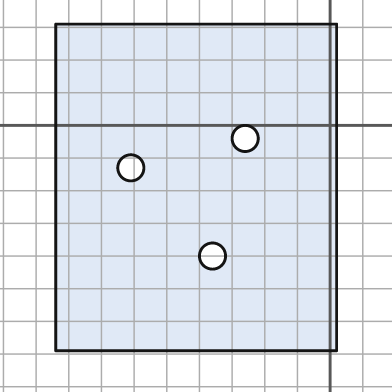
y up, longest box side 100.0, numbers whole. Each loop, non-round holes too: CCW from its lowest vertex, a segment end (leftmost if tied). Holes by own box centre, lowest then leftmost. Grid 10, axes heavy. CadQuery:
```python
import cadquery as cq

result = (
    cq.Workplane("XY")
    .moveTo(-84.0, -69.0)
    .lineTo(2.0, -69.0)
    .lineTo(2.0, 31.0)
    .lineTo(-84.0, 31.0)
    .close()
    .moveTo(-36.0, -40.0)
    .circle(4.0)
    .moveTo(-61.0, -13.0)
    .circle(4.0)
    .moveTo(-26.0, -4.0)
    .circle(4.0)
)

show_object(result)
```